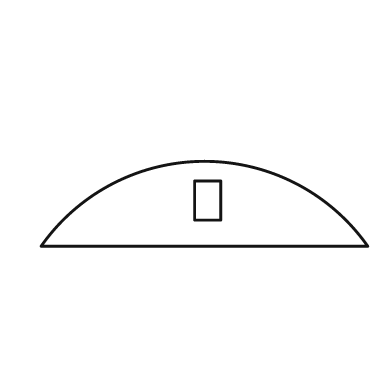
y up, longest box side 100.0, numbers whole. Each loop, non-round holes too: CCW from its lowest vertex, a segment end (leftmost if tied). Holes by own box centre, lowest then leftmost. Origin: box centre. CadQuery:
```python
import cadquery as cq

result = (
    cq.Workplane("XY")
    .moveTo(-50.0, -13.0)
    .lineTo(50.0, -13.0)
    .threePointArc((0.0, 13.0), (-50.0, -13.0))
    .close()
    .moveTo(-3.0, -5.0)
    .lineTo(5.0, -5.0)
    .lineTo(5.0, 7.0)
    .lineTo(-3.0, 7.0)
    .close()
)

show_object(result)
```